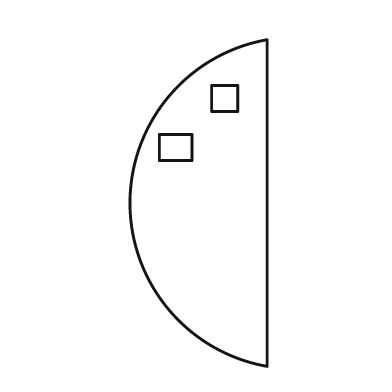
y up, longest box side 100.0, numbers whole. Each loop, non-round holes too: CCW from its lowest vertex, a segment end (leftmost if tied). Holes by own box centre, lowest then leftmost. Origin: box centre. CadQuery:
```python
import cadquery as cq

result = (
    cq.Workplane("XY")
    .moveTo(21.0, -50.0)
    .lineTo(21.0, 50.0)
    .threePointArc((-21.0, 0.0), (21.0, -50.0))
    .close()
    .moveTo(-12.0, 13.0)
    .lineTo(-2.0, 13.0)
    .lineTo(-2.0, 21.0)
    .lineTo(-12.0, 21.0)
    .close()
    .moveTo(4.0, 28.0)
    .lineTo(12.0, 28.0)
    .lineTo(12.0, 36.0)
    .lineTo(4.0, 36.0)
    .close()
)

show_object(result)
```